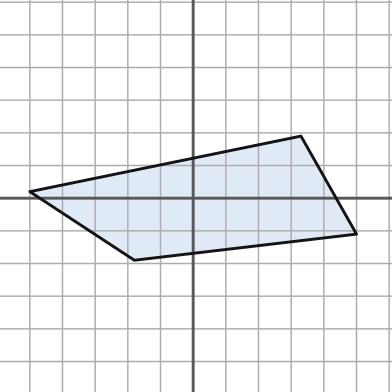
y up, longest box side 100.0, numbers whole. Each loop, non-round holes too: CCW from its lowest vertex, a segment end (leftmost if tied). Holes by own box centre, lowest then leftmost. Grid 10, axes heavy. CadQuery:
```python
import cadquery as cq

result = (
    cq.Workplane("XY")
    .moveTo(-18.0, -19.0)
    .lineTo(50.0, -11.0)
    .lineTo(33.0, 19.0)
    .lineTo(-50.0, 2.0)
    .close()
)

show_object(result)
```